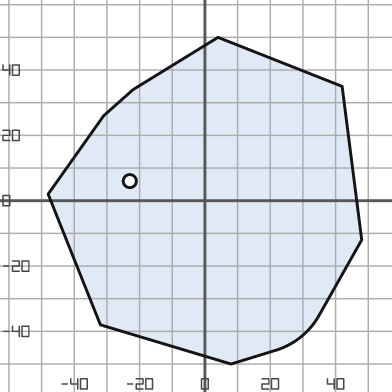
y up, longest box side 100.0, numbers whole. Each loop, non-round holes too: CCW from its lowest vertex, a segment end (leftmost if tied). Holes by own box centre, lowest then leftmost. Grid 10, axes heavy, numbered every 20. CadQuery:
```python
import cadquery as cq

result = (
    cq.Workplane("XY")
    .moveTo(8.0, -50.0)
    .lineTo(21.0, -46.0)
    .threePointArc((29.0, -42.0), (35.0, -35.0))
    .lineTo(48.0, -12.0)
    .lineTo(42.0, 35.0)
    .lineTo(4.0, 50.0)
    .lineTo(-22.0, 34.0)
    .lineTo(-31.0, 26.0)
    .lineTo(-48.0, 2.0)
    .lineTo(-32.0, -38.0)
    .close()
    .moveTo(-23.0, 6.0)
    .circle(2.0)
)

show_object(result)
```